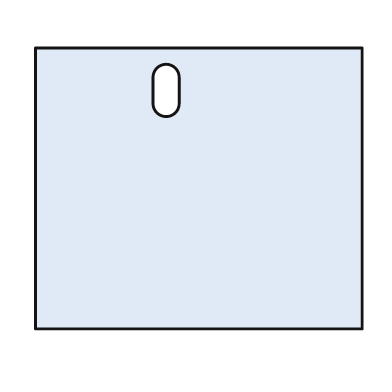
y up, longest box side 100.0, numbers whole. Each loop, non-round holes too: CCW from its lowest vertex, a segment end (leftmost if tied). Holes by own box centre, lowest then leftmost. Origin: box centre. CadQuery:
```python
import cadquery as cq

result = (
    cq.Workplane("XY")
    .moveTo(-50.0, -43.0)
    .lineTo(50.0, -43.0)
    .lineTo(50.0, 43.0)
    .lineTo(-50.0, 43.0)
    .close()
    .moveTo(-14.0, 26.0)
    .threePointArc((-10.0, 22.0), (-6.0, 26.0))
    .lineTo(-6.0, 34.0)
    .threePointArc((-10.0, 38.0), (-14.0, 34.0))
    .close()
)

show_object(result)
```